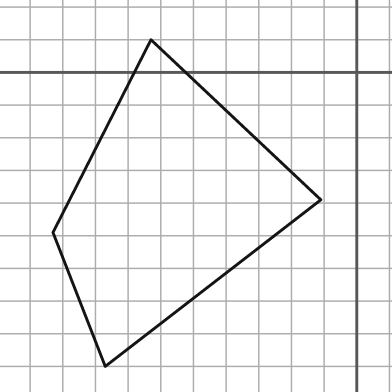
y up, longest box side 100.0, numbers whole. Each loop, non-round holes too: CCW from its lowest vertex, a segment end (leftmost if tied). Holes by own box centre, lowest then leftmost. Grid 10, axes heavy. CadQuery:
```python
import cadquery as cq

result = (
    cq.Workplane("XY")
    .moveTo(-77.0, -90.0)
    .lineTo(-11.0, -39.0)
    .lineTo(-63.0, 10.0)
    .lineTo(-93.0, -49.0)
    .close()
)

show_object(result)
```